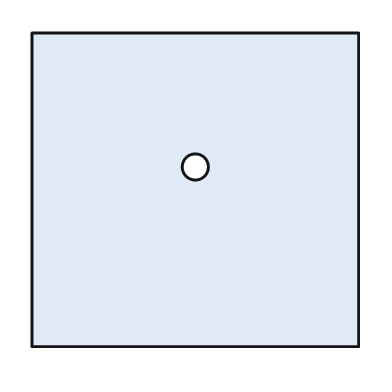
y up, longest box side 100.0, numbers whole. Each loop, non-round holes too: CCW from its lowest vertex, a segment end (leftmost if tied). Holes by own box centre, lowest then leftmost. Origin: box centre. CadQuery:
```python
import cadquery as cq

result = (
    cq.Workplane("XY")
    .moveTo(-50.0, -48.0)
    .lineTo(50.0, -48.0)
    .lineTo(50.0, 48.0)
    .lineTo(-50.0, 48.0)
    .close()
    .moveTo(0.0, 7.0)
    .circle(4.0)
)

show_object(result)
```